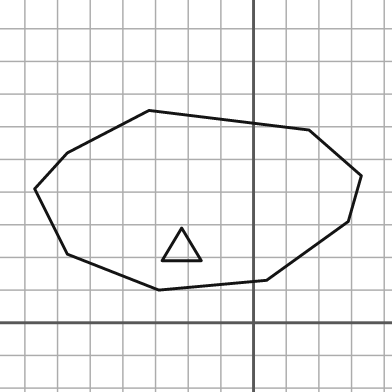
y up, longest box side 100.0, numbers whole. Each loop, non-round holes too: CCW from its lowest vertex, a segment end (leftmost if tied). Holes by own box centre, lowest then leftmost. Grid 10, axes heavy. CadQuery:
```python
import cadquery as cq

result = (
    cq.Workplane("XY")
    .moveTo(-29.0, 10.0)
    .lineTo(4.0, 13.0)
    .lineTo(29.0, 31.0)
    .lineTo(33.0, 45.0)
    .lineTo(17.0, 59.0)
    .lineTo(-32.0, 65.0)
    .lineTo(-57.0, 52.0)
    .lineTo(-67.0, 41.0)
    .lineTo(-57.0, 21.0)
    .close()
    .moveTo(-28.0, 19.0)
    .lineTo(-16.0, 19.0)
    .lineTo(-22.0, 29.0)
    .close()
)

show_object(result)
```